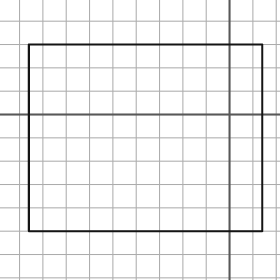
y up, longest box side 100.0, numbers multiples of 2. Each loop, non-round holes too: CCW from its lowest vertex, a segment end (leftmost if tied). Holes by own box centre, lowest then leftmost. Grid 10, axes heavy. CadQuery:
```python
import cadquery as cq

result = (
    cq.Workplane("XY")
    .moveTo(-86.0, -50.0)
    .lineTo(14.0, -50.0)
    .lineTo(14.0, 30.0)
    .lineTo(-86.0, 30.0)
    .close()
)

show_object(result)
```